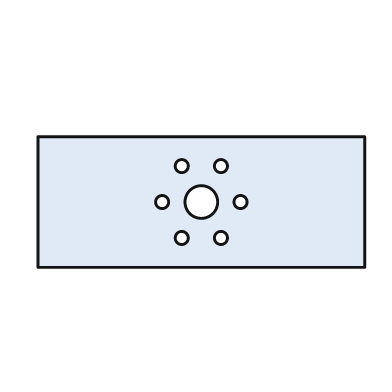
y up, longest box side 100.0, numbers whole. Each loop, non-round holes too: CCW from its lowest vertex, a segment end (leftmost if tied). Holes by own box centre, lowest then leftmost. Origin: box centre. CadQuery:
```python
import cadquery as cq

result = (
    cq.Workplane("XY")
    .moveTo(-50.0, -20.0)
    .lineTo(50.0, -20.0)
    .lineTo(50.0, 20.0)
    .lineTo(-50.0, 20.0)
    .close()
    .moveTo(-6.0, -11.0)
    .circle(2.0)
    .moveTo(6.0, -11.0)
    .circle(2.0)
    .moveTo(-12.0, 0.0)
    .circle(2.0)
    .moveTo(0.0, 0.0)
    .circle(5.0)
    .moveTo(12.0, 0.0)
    .circle(2.0)
    .moveTo(-6.0, 11.0)
    .circle(2.0)
    .moveTo(6.0, 11.0)
    .circle(2.0)
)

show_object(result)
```